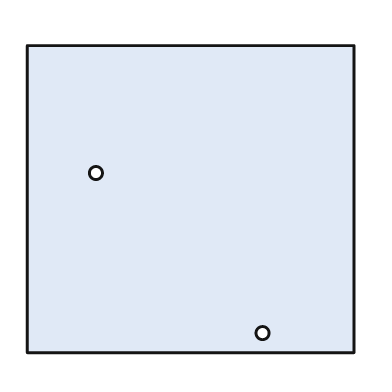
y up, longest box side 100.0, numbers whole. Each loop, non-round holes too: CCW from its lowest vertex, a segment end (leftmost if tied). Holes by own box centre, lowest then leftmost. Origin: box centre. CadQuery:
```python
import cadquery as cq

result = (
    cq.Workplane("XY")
    .moveTo(-50.0, -47.0)
    .lineTo(50.0, -47.0)
    .lineTo(50.0, 47.0)
    .lineTo(-50.0, 47.0)
    .close()
    .moveTo(22.0, -41.0)
    .circle(2.0)
    .moveTo(-29.0, 8.0)
    .circle(2.0)
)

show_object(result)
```